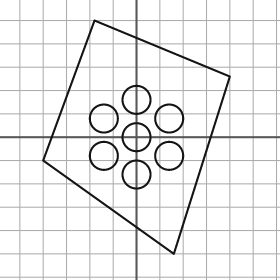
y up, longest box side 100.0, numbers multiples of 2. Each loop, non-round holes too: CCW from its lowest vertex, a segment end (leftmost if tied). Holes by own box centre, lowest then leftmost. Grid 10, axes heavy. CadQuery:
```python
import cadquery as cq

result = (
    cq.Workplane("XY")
    .moveTo(16.0, -50.0)
    .lineTo(40.0, 26.0)
    .lineTo(-18.0, 50.0)
    .lineTo(-40.0, -10.0)
    .close()
    .moveTo(0.0, -16.0)
    .circle(6.0)
    .moveTo(-14.0, -8.0)
    .circle(6.0)
    .moveTo(14.0, -8.0)
    .circle(6.0)
    .moveTo(0.0, 0.0)
    .circle(6.0)
    .moveTo(-14.0, 8.0)
    .circle(6.0)
    .moveTo(14.0, 8.0)
    .circle(6.0)
    .moveTo(0.0, 16.0)
    .circle(6.0)
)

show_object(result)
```